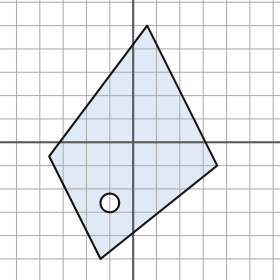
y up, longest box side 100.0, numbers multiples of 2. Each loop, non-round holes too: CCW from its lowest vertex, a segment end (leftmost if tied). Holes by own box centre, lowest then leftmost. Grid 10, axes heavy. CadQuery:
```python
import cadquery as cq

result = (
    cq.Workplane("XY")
    .moveTo(-14.0, -50.0)
    .lineTo(36.0, -10.0)
    .lineTo(6.0, 50.0)
    .lineTo(-36.0, -6.0)
    .close()
    .moveTo(-10.0, -26.0)
    .circle(4.0)
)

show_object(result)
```